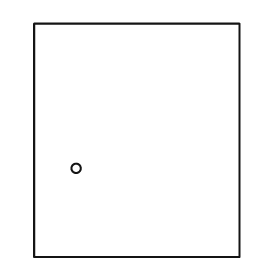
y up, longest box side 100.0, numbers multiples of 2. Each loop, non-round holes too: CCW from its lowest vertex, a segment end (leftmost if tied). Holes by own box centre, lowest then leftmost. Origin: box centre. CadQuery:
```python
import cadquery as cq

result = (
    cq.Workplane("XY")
    .moveTo(-44.0, -50.0)
    .lineTo(44.0, -50.0)
    .lineTo(44.0, 50.0)
    .lineTo(-44.0, 50.0)
    .close()
    .moveTo(-26.0, -12.0)
    .circle(2.0)
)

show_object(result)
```